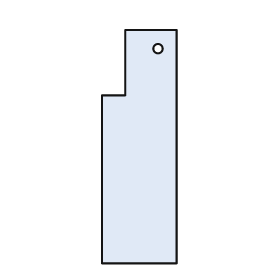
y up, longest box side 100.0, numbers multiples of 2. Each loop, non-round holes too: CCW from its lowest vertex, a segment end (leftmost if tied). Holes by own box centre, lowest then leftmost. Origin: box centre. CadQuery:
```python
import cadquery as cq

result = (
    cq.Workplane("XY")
    .moveTo(-16.0, -50.0)
    .lineTo(16.0, -50.0)
    .lineTo(16.0, 50.0)
    .lineTo(-6.0, 50.0)
    .lineTo(-6.0, 22.0)
    .lineTo(-16.0, 22.0)
    .close()
    .moveTo(8.0, 42.0)
    .circle(2.0)
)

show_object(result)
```